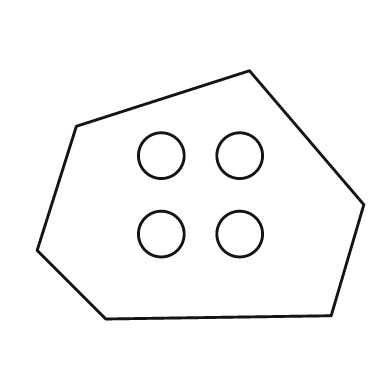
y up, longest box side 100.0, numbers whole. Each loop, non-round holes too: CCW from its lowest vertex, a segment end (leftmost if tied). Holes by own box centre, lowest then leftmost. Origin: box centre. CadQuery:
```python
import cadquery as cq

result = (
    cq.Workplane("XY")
    .moveTo(-29.0, -38.0)
    .lineTo(40.0, -37.0)
    .lineTo(50.0, -3.0)
    .lineTo(15.0, 38.0)
    .lineTo(-38.0, 21.0)
    .lineTo(-50.0, -17.0)
    .close()
    .moveTo(-12.0, -12.0)
    .circle(7.0)
    .moveTo(12.0, -12.0)
    .circle(7.0)
    .moveTo(-12.0, 12.0)
    .circle(7.0)
    .moveTo(12.0, 12.0)
    .circle(7.0)
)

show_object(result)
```